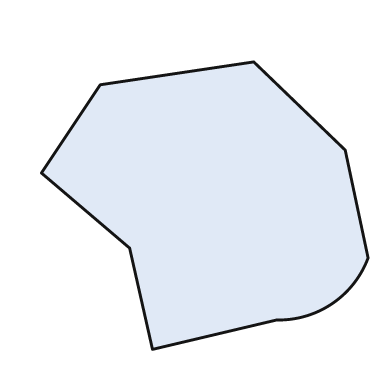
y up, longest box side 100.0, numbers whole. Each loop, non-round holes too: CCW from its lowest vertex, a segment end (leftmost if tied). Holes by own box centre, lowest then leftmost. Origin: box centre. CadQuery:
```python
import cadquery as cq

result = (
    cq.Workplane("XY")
    .moveTo(-16.0, -44.0)
    .lineTo(22.0, -35.0)
    .threePointArc((39.0, -30.0), (50.0, -16.0))
    .lineTo(43.0, 17.0)
    .lineTo(15.0, 44.0)
    .lineTo(-32.0, 37.0)
    .lineTo(-50.0, 10.0)
    .lineTo(-23.0, -13.0)
    .close()
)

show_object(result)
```